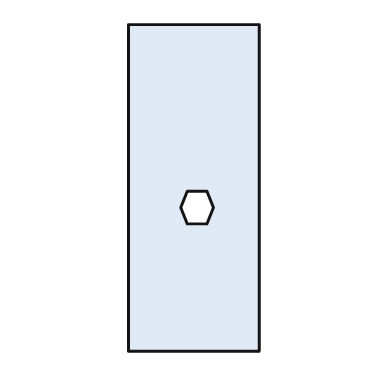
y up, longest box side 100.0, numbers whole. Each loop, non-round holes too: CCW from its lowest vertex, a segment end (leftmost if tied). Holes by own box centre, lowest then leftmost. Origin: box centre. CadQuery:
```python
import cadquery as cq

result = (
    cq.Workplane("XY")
    .moveTo(-20.0, -50.0)
    .lineTo(20.0, -50.0)
    .lineTo(20.0, 50.0)
    .lineTo(-20.0, 50.0)
    .close()
    .moveTo(-2.0, -11.0)
    .lineTo(4.0, -11.0)
    .lineTo(6.0, -6.0)
    .lineTo(4.0, -1.0)
    .lineTo(-2.0, -1.0)
    .lineTo(-4.0, -6.0)
    .close()
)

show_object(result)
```